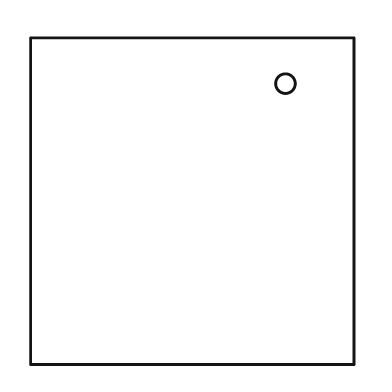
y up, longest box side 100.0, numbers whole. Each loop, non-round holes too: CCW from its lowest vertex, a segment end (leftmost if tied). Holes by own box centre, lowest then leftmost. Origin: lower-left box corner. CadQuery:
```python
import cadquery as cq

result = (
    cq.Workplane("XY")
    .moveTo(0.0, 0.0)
    .lineTo(99.0, 0.0)
    .lineTo(99.0, 100.0)
    .lineTo(0.0, 100.0)
    .close()
    .moveTo(78.0, 86.0)
    .circle(3.0)
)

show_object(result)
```